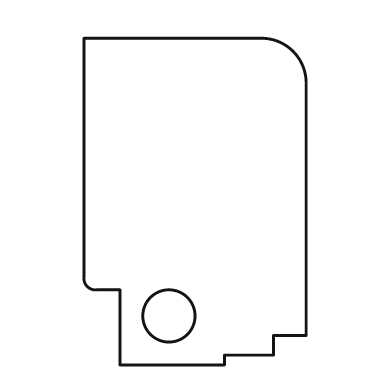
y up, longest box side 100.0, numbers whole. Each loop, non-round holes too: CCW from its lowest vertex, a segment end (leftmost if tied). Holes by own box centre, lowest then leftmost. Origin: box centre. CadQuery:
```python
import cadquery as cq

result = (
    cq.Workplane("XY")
    .moveTo(-23.0, -50.0)
    .lineTo(9.0, -50.0)
    .lineTo(9.0, -47.0)
    .lineTo(24.0, -47.0)
    .lineTo(24.0, -41.0)
    .lineTo(34.0, -41.0)
    .lineTo(34.0, 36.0)
    .threePointArc((30.0, 46.0), (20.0, 50.0))
    .lineTo(-34.0, 50.0)
    .lineTo(-34.0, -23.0)
    .threePointArc((-33.0, -26.0), (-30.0, -27.0))
    .lineTo(-23.0, -27.0)
    .close()
    .moveTo(-8.0, -35.0)
    .circle(8.0)
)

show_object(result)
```